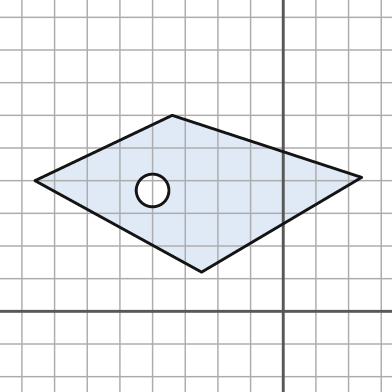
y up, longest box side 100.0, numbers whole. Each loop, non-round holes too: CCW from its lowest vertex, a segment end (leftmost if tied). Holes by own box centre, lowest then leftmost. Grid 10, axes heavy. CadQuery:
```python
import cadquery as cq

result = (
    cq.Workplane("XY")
    .moveTo(-25.0, 12.0)
    .lineTo(24.0, 41.0)
    .lineTo(-34.0, 60.0)
    .lineTo(-76.0, 40.0)
    .close()
    .moveTo(-40.0, 37.0)
    .circle(5.0)
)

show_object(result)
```